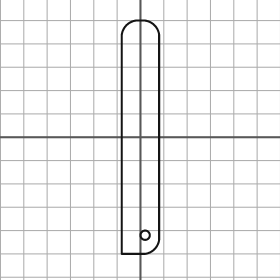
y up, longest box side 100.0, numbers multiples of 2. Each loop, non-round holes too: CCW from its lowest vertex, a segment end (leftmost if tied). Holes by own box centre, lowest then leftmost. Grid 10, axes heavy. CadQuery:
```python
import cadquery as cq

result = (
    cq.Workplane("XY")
    .moveTo(-8.0, -50.0)
    .lineTo(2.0, -50.0)
    .threePointArc((6.0, -48.0), (8.0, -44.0))
    .lineTo(8.0, 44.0)
    .threePointArc((6.0, 48.0), (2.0, 50.0))
    .lineTo(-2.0, 50.0)
    .threePointArc((-6.0, 48.0), (-8.0, 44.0))
    .close()
    .moveTo(2.0, -42.0)
    .circle(2.0)
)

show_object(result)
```